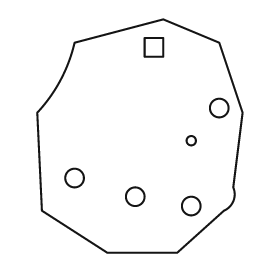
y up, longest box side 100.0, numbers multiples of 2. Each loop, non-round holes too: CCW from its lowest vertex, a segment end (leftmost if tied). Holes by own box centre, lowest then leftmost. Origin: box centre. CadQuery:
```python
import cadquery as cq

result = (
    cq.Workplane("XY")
    .moveTo(-14.0, -50.0)
    .lineTo(16.0, -50.0)
    .lineTo(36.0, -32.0)
    .threePointArc((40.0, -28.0), (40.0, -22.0))
    .lineTo(44.0, 10.0)
    .lineTo(34.0, 40.0)
    .lineTo(10.0, 50.0)
    .lineTo(-28.0, 40.0)
    .threePointArc((-34.0, 24.0), (-44.0, 10.0))
    .lineTo(-42.0, -32.0)
    .close()
    .moveTo(22.0, -30.0)
    .circle(4.0)
    .moveTo(-2.0, -26.0)
    .circle(4.0)
    .moveTo(-28.0, -18.0)
    .circle(4.0)
    .moveTo(22.0, -2.0)
    .circle(2.0)
    .moveTo(34.0, 12.0)
    .circle(4.0)
    .moveTo(2.0, 34.0)
    .lineTo(10.0, 34.0)
    .lineTo(10.0, 42.0)
    .lineTo(2.0, 42.0)
    .close()
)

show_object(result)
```